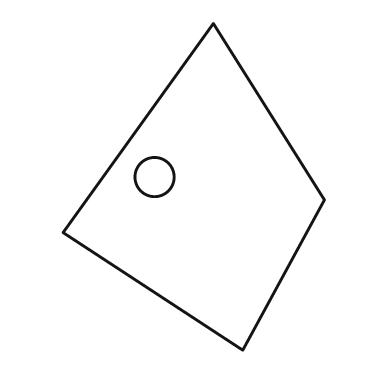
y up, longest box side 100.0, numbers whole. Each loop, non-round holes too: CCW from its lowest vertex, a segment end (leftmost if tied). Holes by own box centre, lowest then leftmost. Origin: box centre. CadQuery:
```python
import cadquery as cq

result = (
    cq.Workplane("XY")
    .moveTo(15.0, -50.0)
    .lineTo(40.0, -4.0)
    .lineTo(6.0, 50.0)
    .lineTo(-40.0, -14.0)
    .close()
    .moveTo(-12.0, 3.0)
    .circle(6.0)
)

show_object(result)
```